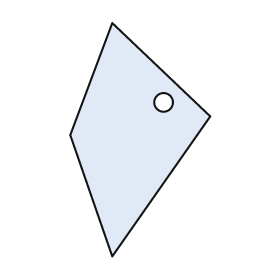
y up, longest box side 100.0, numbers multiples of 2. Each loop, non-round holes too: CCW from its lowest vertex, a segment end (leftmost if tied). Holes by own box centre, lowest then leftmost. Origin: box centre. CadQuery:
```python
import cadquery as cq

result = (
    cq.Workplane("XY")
    .moveTo(-12.0, -50.0)
    .lineTo(30.0, 10.0)
    .lineTo(-12.0, 50.0)
    .lineTo(-30.0, 2.0)
    .close()
    .moveTo(10.0, 16.0)
    .circle(4.0)
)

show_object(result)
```